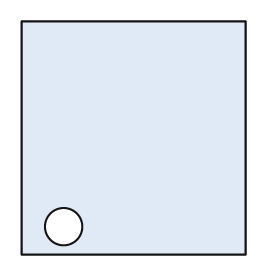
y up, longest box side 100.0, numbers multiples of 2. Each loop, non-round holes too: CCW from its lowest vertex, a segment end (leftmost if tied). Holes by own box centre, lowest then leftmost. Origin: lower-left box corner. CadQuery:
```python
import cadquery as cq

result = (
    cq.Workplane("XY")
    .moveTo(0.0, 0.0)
    .lineTo(96.0, 0.0)
    .lineTo(96.0, 100.0)
    .lineTo(0.0, 100.0)
    .close()
    .moveTo(18.0, 12.0)
    .circle(8.0)
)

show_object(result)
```